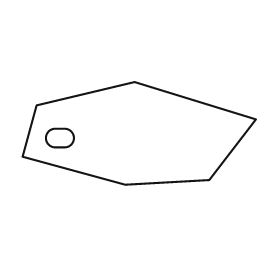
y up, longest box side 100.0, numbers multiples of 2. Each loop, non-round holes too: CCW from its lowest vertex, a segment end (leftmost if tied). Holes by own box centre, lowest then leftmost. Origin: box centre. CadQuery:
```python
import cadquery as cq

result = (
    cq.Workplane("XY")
    .moveTo(-6.0, -22.0)
    .lineTo(30.0, -20.0)
    .lineTo(50.0, 6.0)
    .lineTo(-2.0, 22.0)
    .lineTo(-44.0, 12.0)
    .lineTo(-50.0, -10.0)
    .close()
    .moveTo(-36.0, -6.0)
    .lineTo(-32.0, -6.0)
    .threePointArc((-28.0, -2.0), (-32.0, 2.0))
    .lineTo(-36.0, 2.0)
    .threePointArc((-40.0, -2.0), (-36.0, -6.0))
    .close()
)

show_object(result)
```